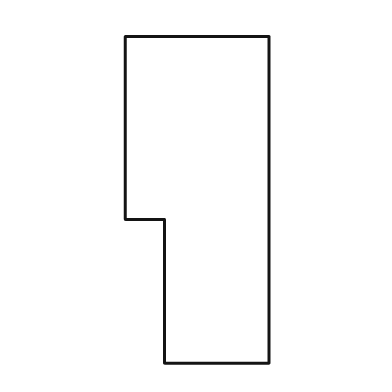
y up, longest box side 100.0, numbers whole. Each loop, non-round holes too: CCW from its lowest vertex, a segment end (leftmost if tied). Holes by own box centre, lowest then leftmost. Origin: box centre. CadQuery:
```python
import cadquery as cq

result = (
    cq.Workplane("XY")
    .moveTo(-10.0, -50.0)
    .lineTo(22.0, -50.0)
    .lineTo(22.0, 50.0)
    .lineTo(-22.0, 50.0)
    .lineTo(-22.0, -6.0)
    .lineTo(-10.0, -6.0)
    .close()
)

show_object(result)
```